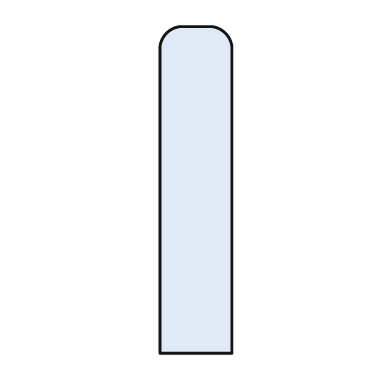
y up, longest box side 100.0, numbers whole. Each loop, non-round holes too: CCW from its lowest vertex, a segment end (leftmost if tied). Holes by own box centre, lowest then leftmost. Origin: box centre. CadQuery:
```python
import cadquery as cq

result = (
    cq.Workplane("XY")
    .moveTo(-11.0, -50.0)
    .lineTo(11.0, -50.0)
    .lineTo(11.0, 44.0)
    .threePointArc((9.0, 48.0), (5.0, 50.0))
    .lineTo(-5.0, 50.0)
    .threePointArc((-9.0, 48.0), (-11.0, 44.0))
    .close()
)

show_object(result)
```